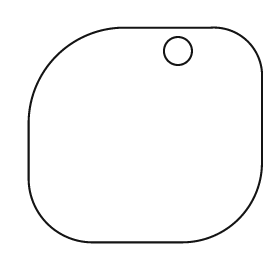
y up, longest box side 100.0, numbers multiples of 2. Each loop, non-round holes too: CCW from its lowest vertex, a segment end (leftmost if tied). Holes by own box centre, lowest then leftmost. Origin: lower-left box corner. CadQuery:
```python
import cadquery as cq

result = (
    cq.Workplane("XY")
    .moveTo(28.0, 0.0)
    .lineTo(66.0, 0.0)
    .threePointArc((90.0, 10.0), (100.0, 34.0))
    .lineTo(100.0, 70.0)
    .threePointArc((94.0, 86.0), (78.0, 92.0))
    .lineTo(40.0, 92.0)
    .threePointArc((12.0, 80.0), (0.0, 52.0))
    .lineTo(0.0, 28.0)
    .threePointArc((8.0, 8.0), (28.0, 0.0))
    .close()
    .moveTo(64.0, 82.0)
    .circle(6.0)
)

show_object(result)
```